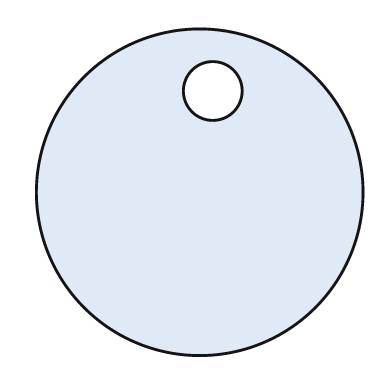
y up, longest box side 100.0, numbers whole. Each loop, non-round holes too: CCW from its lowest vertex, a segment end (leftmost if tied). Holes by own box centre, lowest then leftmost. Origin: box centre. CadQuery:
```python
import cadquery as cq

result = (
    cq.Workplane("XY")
    .moveTo(0.0, 0.0)
    .circle(50.0)
    .moveTo(4.0, 31.0)
    .circle(9.0)
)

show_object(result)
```